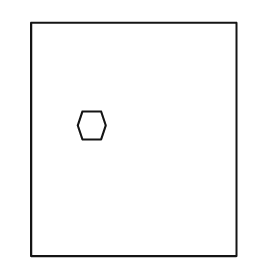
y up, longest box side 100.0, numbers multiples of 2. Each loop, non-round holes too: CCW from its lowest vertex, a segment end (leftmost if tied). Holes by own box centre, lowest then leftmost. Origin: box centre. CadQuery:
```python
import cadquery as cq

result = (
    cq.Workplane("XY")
    .moveTo(-44.0, -50.0)
    .lineTo(44.0, -50.0)
    .lineTo(44.0, 50.0)
    .lineTo(-44.0, 50.0)
    .close()
    .moveTo(-22.0, 0.0)
    .lineTo(-14.0, 0.0)
    .lineTo(-12.0, 6.0)
    .lineTo(-14.0, 12.0)
    .lineTo(-22.0, 12.0)
    .lineTo(-24.0, 6.0)
    .close()
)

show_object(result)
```